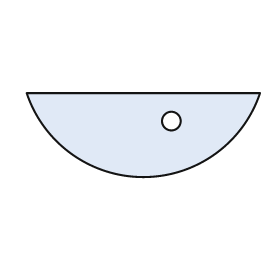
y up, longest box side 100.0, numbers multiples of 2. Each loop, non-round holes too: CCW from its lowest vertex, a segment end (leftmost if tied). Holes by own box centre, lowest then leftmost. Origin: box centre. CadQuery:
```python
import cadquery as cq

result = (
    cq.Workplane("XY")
    .moveTo(-50.0, 18.0)
    .threePointArc((0.0, -18.0), (50.0, 18.0))
    .close()
    .moveTo(12.0, 6.0)
    .circle(4.0)
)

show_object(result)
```